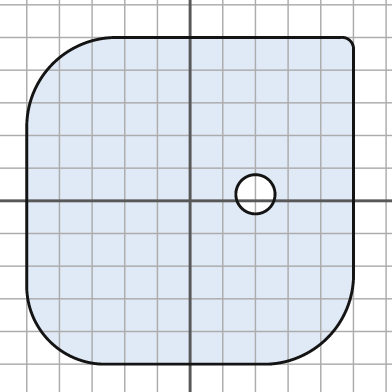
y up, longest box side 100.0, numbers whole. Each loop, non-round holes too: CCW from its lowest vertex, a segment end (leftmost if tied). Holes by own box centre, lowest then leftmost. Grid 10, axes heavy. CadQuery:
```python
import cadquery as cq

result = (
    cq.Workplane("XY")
    .moveTo(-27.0, -50.0)
    .lineTo(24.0, -50.0)
    .threePointArc((42.0, -42.0), (50.0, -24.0))
    .lineTo(50.0, 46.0)
    .threePointArc((49.0, 49.0), (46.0, 50.0))
    .lineTo(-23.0, 50.0)
    .threePointArc((-42.0, 42.0), (-50.0, 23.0))
    .lineTo(-50.0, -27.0)
    .threePointArc((-43.0, -43.0), (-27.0, -50.0))
    .close()
    .moveTo(20.0, 2.0)
    .circle(6.0)
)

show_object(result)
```